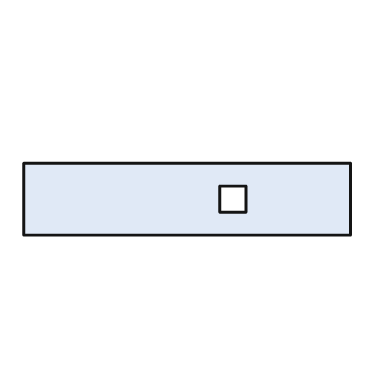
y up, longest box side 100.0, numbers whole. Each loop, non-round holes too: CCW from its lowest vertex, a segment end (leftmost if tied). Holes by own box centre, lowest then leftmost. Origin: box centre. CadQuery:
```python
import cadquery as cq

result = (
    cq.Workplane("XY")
    .moveTo(-50.0, -11.0)
    .lineTo(50.0, -11.0)
    .lineTo(50.0, 11.0)
    .lineTo(-50.0, 11.0)
    .close()
    .moveTo(10.0, -4.0)
    .lineTo(18.0, -4.0)
    .lineTo(18.0, 4.0)
    .lineTo(10.0, 4.0)
    .close()
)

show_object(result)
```